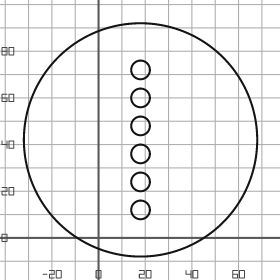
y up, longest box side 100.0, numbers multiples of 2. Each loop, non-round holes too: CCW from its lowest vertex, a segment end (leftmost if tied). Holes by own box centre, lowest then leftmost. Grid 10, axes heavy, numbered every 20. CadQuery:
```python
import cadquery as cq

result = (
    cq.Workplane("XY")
    .moveTo(18.0, 42.0)
    .circle(50.0)
    .moveTo(18.0, 12.0)
    .circle(4.0)
    .moveTo(18.0, 24.0)
    .circle(4.0)
    .moveTo(18.0, 36.0)
    .circle(4.0)
    .moveTo(18.0, 48.0)
    .circle(4.0)
    .moveTo(18.0, 60.0)
    .circle(4.0)
    .moveTo(18.0, 72.0)
    .circle(4.0)
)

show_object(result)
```